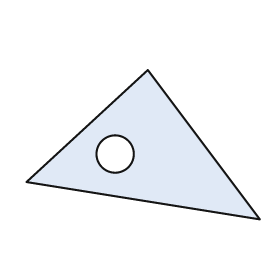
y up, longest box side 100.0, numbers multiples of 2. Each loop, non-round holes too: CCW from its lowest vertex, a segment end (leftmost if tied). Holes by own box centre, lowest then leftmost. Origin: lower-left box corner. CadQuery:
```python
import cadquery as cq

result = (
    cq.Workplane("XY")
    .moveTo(100.0, 0.0)
    .lineTo(52.0, 64.0)
    .lineTo(0.0, 16.0)
    .close()
    .moveTo(38.0, 28.0)
    .circle(8.0)
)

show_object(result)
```